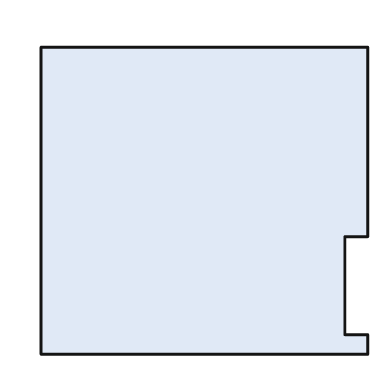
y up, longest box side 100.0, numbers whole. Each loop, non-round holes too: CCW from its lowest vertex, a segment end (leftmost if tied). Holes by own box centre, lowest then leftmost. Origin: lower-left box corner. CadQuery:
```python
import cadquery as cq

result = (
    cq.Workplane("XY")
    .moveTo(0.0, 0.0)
    .lineTo(100.0, 0.0)
    .lineTo(100.0, 6.0)
    .lineTo(93.0, 6.0)
    .lineTo(93.0, 36.0)
    .lineTo(100.0, 36.0)
    .lineTo(100.0, 94.0)
    .lineTo(0.0, 94.0)
    .close()
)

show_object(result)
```